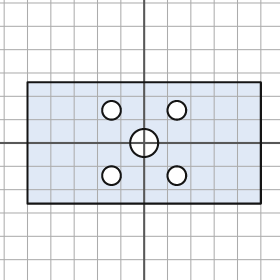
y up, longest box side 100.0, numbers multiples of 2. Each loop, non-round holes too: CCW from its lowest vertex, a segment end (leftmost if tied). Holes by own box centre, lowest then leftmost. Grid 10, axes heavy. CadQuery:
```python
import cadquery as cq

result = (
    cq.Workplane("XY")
    .moveTo(-50.0, -26.0)
    .lineTo(50.0, -26.0)
    .lineTo(50.0, 26.0)
    .lineTo(-50.0, 26.0)
    .close()
    .moveTo(-14.0, -14.0)
    .circle(4.0)
    .moveTo(14.0, -14.0)
    .circle(4.0)
    .moveTo(0.0, 0.0)
    .circle(6.0)
    .moveTo(-14.0, 14.0)
    .circle(4.0)
    .moveTo(14.0, 14.0)
    .circle(4.0)
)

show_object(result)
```